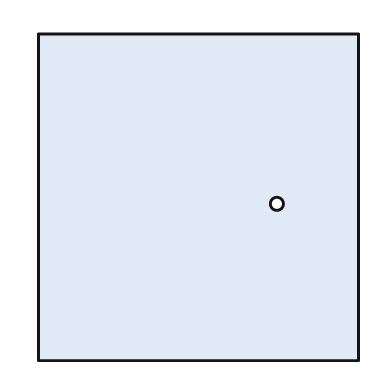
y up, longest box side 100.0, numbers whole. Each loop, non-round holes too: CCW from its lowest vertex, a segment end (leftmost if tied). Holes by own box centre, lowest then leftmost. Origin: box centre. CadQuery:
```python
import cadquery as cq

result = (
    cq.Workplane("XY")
    .moveTo(-49.0, -50.0)
    .lineTo(49.0, -50.0)
    .lineTo(49.0, 50.0)
    .lineTo(-49.0, 50.0)
    .close()
    .moveTo(24.0, -2.0)
    .circle(2.0)
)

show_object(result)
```